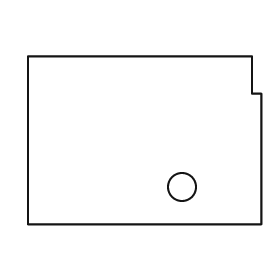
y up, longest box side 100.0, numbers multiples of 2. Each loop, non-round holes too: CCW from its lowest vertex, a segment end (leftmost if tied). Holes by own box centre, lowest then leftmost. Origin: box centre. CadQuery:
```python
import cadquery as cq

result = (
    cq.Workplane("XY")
    .moveTo(-50.0, -36.0)
    .lineTo(50.0, -36.0)
    .lineTo(50.0, 20.0)
    .lineTo(46.0, 20.0)
    .lineTo(46.0, 36.0)
    .lineTo(-50.0, 36.0)
    .close()
    .moveTo(16.0, -20.0)
    .circle(6.0)
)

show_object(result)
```